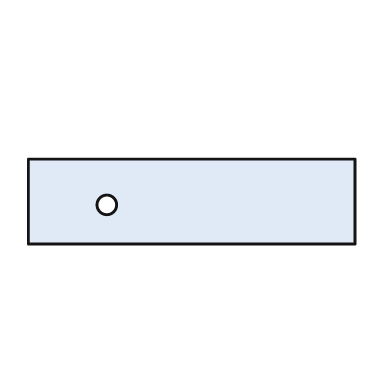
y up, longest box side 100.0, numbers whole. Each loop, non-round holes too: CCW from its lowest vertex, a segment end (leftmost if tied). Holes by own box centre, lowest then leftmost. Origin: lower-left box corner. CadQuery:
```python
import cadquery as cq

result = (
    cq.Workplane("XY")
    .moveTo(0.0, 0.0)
    .lineTo(100.0, 0.0)
    .lineTo(100.0, 26.0)
    .lineTo(0.0, 26.0)
    .close()
    .moveTo(24.0, 12.0)
    .circle(3.0)
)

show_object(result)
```